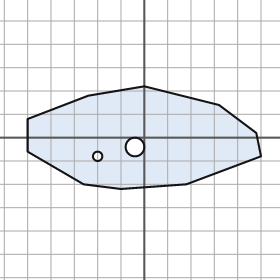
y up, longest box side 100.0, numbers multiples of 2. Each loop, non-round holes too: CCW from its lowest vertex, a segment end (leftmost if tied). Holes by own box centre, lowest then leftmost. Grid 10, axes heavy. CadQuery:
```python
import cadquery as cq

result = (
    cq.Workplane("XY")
    .moveTo(-10.0, -22.0)
    .lineTo(18.0, -20.0)
    .lineTo(50.0, -8.0)
    .lineTo(48.0, 2.0)
    .lineTo(32.0, 14.0)
    .lineTo(0.0, 22.0)
    .lineTo(-24.0, 18.0)
    .lineTo(-50.0, 8.0)
    .lineTo(-50.0, -6.0)
    .lineTo(-26.0, -20.0)
    .close()
    .moveTo(-20.0, -8.0)
    .circle(2.0)
    .moveTo(-4.0, -4.0)
    .circle(4.0)
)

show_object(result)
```